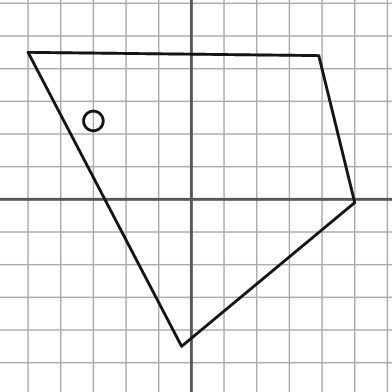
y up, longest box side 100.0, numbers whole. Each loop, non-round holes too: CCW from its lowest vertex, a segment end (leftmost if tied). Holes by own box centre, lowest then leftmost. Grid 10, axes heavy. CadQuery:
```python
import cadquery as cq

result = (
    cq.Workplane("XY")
    .moveTo(-3.0, -45.0)
    .lineTo(50.0, -1.0)
    .lineTo(39.0, 44.0)
    .lineTo(-50.0, 45.0)
    .close()
    .moveTo(-30.0, 24.0)
    .circle(3.0)
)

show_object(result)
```